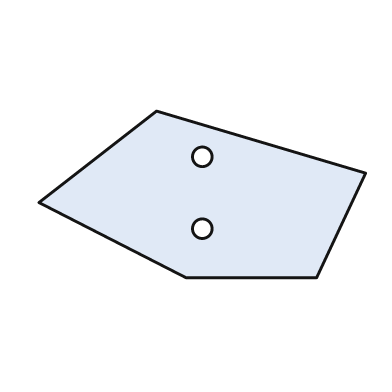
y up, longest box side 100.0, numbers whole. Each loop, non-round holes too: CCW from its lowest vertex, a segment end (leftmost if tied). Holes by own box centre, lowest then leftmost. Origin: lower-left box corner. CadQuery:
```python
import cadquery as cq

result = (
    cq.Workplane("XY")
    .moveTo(45.0, 0.0)
    .lineTo(85.0, 0.0)
    .lineTo(100.0, 32.0)
    .lineTo(36.0, 51.0)
    .lineTo(0.0, 23.0)
    .close()
    .moveTo(50.0, 15.0)
    .circle(3.0)
    .moveTo(50.0, 37.0)
    .circle(3.0)
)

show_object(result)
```